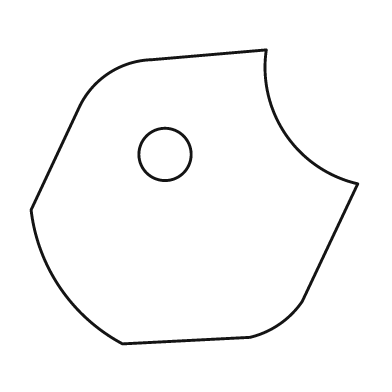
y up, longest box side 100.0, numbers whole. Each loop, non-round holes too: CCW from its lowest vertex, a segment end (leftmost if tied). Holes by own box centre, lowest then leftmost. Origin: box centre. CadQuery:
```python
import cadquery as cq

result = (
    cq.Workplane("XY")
    .moveTo(-22.0, -45.0)
    .lineTo(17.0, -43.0)
    .threePointArc((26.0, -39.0), (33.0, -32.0))
    .lineTo(50.0, 4.0)
    .threePointArc((28.0, 19.0), (22.0, 45.0))
    .lineTo(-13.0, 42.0)
    .threePointArc((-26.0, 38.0), (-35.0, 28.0))
    .lineTo(-50.0, -4.0)
    .threePointArc((-41.0, -28.0), (-22.0, -45.0))
    .close()
    .moveTo(-9.0, 13.0)
    .circle(8.0)
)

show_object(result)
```